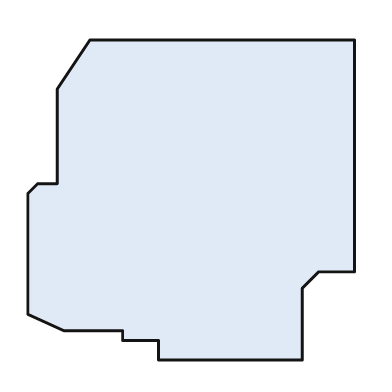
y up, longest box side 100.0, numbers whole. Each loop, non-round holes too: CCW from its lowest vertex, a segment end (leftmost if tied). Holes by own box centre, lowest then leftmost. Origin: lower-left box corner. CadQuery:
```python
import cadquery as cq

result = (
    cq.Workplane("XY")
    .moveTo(40.0, 0.0)
    .lineTo(84.0, 0.0)
    .lineTo(84.0, 22.0)
    .lineTo(89.0, 27.0)
    .lineTo(100.0, 27.0)
    .lineTo(100.0, 98.0)
    .lineTo(19.0, 98.0)
    .lineTo(9.0, 83.0)
    .lineTo(9.0, 54.0)
    .lineTo(3.0, 54.0)
    .lineTo(0.0, 51.0)
    .lineTo(0.0, 14.0)
    .lineTo(11.0, 9.0)
    .lineTo(29.0, 9.0)
    .lineTo(29.0, 6.0)
    .lineTo(40.0, 6.0)
    .close()
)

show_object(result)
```